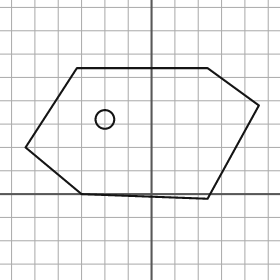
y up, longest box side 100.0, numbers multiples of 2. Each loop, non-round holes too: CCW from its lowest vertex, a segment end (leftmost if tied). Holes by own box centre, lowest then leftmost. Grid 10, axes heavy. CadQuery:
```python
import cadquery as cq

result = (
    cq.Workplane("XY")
    .moveTo(24.0, -2.0)
    .lineTo(46.0, 38.0)
    .lineTo(24.0, 54.0)
    .lineTo(-32.0, 54.0)
    .lineTo(-54.0, 20.0)
    .lineTo(-30.0, 0.0)
    .close()
    .moveTo(-20.0, 32.0)
    .circle(4.0)
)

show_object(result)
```